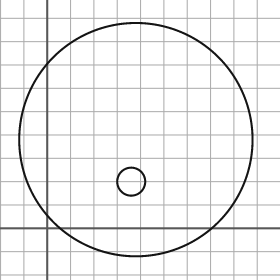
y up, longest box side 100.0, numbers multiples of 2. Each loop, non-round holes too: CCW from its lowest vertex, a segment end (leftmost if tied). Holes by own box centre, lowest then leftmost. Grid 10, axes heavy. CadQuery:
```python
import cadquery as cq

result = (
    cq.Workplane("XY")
    .moveTo(38.0, 38.0)
    .circle(50.0)
    .moveTo(36.0, 20.0)
    .circle(6.0)
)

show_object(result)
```